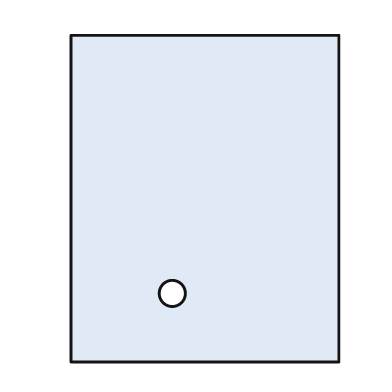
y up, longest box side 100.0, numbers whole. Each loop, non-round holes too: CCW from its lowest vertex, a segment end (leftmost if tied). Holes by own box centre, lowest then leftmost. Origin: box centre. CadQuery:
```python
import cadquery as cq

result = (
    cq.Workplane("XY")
    .moveTo(-41.0, -50.0)
    .lineTo(41.0, -50.0)
    .lineTo(41.0, 50.0)
    .lineTo(-41.0, 50.0)
    .close()
    .moveTo(-10.0, -29.0)
    .circle(4.0)
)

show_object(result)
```